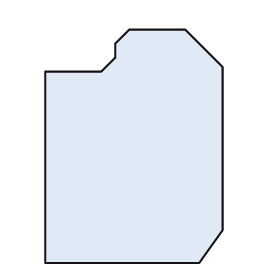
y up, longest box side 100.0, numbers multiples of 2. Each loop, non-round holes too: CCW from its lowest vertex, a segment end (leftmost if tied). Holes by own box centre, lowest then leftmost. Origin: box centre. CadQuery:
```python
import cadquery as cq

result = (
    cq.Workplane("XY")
    .moveTo(-38.0, -50.0)
    .lineTo(28.0, -50.0)
    .lineTo(38.0, -36.0)
    .lineTo(38.0, 34.0)
    .lineTo(22.0, 50.0)
    .lineTo(-2.0, 50.0)
    .lineTo(-8.0, 44.0)
    .lineTo(-8.0, 38.0)
    .lineTo(-14.0, 32.0)
    .lineTo(-38.0, 32.0)
    .close()
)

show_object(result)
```